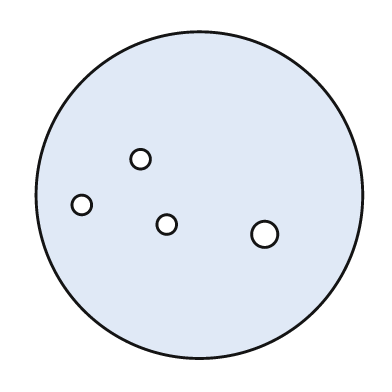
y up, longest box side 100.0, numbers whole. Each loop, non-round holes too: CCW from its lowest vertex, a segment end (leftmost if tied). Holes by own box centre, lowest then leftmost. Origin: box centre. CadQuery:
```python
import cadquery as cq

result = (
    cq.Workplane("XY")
    .moveTo(0.0, 0.0)
    .circle(50.0)
    .moveTo(20.0, -12.0)
    .circle(4.0)
    .moveTo(-10.0, -9.0)
    .circle(3.0)
    .moveTo(-36.0, -3.0)
    .circle(3.0)
    .moveTo(-18.0, 11.0)
    .circle(3.0)
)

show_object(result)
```